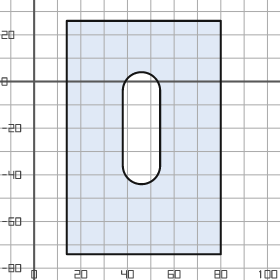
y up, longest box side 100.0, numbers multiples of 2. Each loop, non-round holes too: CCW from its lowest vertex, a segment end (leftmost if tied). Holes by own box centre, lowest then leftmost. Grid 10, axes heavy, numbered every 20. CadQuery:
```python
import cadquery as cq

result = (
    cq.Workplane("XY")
    .moveTo(14.0, -74.0)
    .lineTo(80.0, -74.0)
    .lineTo(80.0, 26.0)
    .lineTo(14.0, 26.0)
    .close()
    .moveTo(38.0, -36.0)
    .threePointArc((46.0, -44.0), (54.0, -36.0))
    .lineTo(54.0, -4.0)
    .threePointArc((46.0, 4.0), (38.0, -4.0))
    .close()
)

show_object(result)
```